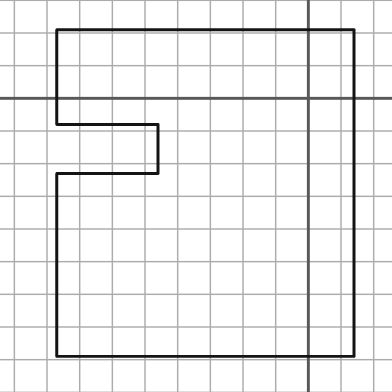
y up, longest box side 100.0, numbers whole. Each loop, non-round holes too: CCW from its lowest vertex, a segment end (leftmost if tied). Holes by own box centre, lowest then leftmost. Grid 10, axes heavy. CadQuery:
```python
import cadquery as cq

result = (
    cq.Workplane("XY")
    .moveTo(-77.0, -79.0)
    .lineTo(14.0, -79.0)
    .lineTo(14.0, 21.0)
    .lineTo(-77.0, 21.0)
    .lineTo(-77.0, -8.0)
    .lineTo(-46.0, -8.0)
    .lineTo(-46.0, -23.0)
    .lineTo(-77.0, -23.0)
    .close()
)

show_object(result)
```